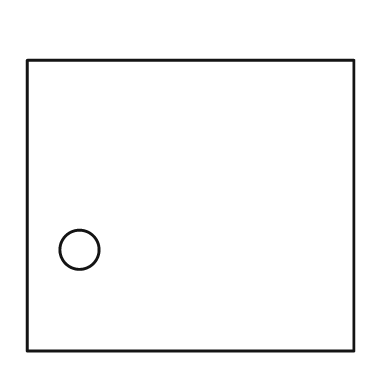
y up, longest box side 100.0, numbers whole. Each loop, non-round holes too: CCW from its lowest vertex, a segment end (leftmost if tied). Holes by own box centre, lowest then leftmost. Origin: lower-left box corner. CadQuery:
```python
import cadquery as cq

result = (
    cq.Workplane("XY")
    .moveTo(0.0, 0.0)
    .lineTo(100.0, 0.0)
    .lineTo(100.0, 89.0)
    .lineTo(0.0, 89.0)
    .close()
    .moveTo(16.0, 31.0)
    .circle(6.0)
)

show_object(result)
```